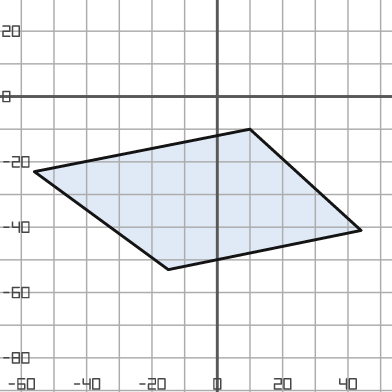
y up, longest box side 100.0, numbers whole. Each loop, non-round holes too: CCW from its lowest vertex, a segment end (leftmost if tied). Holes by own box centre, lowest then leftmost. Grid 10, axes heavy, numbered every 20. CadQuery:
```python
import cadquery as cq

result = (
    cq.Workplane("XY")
    .moveTo(-15.0, -53.0)
    .lineTo(44.0, -41.0)
    .lineTo(10.0, -10.0)
    .lineTo(-56.0, -23.0)
    .close()
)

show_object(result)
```